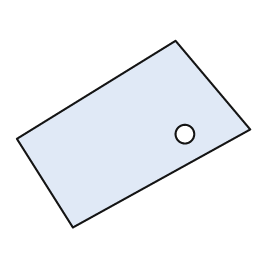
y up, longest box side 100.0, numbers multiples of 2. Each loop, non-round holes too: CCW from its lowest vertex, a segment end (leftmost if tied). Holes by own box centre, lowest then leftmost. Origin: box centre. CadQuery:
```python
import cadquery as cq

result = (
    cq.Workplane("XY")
    .moveTo(-26.0, -40.0)
    .lineTo(50.0, 2.0)
    .lineTo(18.0, 40.0)
    .lineTo(-50.0, -2.0)
    .close()
    .moveTo(22.0, 0.0)
    .circle(4.0)
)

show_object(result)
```